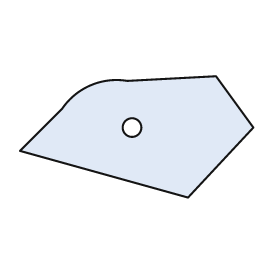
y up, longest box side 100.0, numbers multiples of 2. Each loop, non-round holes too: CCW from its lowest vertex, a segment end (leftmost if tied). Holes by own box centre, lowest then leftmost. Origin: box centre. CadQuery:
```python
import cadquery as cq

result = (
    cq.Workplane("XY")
    .moveTo(22.0, -26.0)
    .lineTo(50.0, 4.0)
    .lineTo(34.0, 26.0)
    .lineTo(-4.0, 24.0)
    .threePointArc((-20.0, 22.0), (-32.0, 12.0))
    .lineTo(-50.0, -6.0)
    .close()
    .moveTo(-2.0, 4.0)
    .circle(4.0)
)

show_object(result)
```